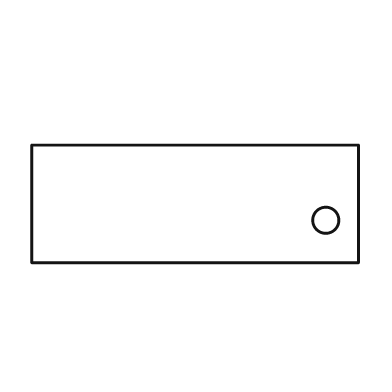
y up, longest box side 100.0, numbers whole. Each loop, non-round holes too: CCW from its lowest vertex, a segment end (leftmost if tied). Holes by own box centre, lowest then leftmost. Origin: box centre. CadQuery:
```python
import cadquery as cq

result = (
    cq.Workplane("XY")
    .moveTo(-50.0, -18.0)
    .lineTo(50.0, -18.0)
    .lineTo(50.0, 18.0)
    .lineTo(-50.0, 18.0)
    .close()
    .moveTo(40.0, -5.0)
    .circle(4.0)
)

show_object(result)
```